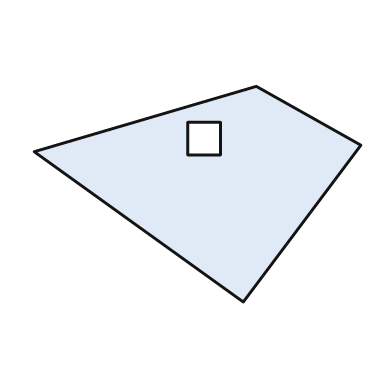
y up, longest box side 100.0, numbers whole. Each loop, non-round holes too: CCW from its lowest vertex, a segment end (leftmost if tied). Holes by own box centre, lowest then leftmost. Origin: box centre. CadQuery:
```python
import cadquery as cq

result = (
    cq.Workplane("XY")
    .moveTo(14.0, -33.0)
    .lineTo(50.0, 15.0)
    .lineTo(18.0, 33.0)
    .lineTo(-50.0, 13.0)
    .close()
    .moveTo(-3.0, 12.0)
    .lineTo(7.0, 12.0)
    .lineTo(7.0, 22.0)
    .lineTo(-3.0, 22.0)
    .close()
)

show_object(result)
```